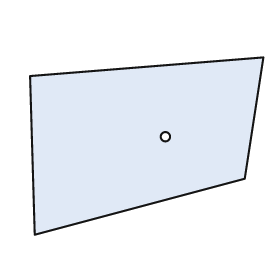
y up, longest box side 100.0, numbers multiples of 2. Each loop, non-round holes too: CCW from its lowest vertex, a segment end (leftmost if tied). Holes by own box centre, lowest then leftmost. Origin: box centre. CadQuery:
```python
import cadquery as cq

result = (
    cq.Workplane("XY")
    .moveTo(-48.0, -38.0)
    .lineTo(42.0, -14.0)
    .lineTo(50.0, 38.0)
    .lineTo(-50.0, 30.0)
    .close()
    .moveTo(8.0, 4.0)
    .circle(2.0)
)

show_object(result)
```